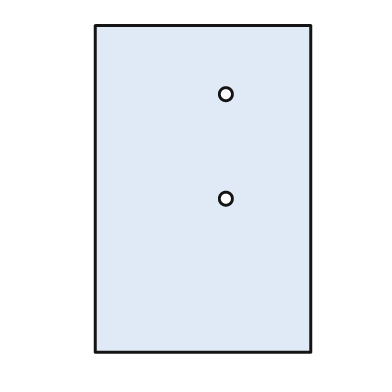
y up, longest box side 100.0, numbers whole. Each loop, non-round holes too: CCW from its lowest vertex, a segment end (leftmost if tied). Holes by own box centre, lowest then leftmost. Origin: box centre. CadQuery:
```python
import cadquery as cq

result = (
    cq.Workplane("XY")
    .moveTo(-33.0, -50.0)
    .lineTo(33.0, -50.0)
    .lineTo(33.0, 50.0)
    .lineTo(-33.0, 50.0)
    .close()
    .moveTo(7.0, -3.0)
    .circle(2.0)
    .moveTo(7.0, 29.0)
    .circle(2.0)
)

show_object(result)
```